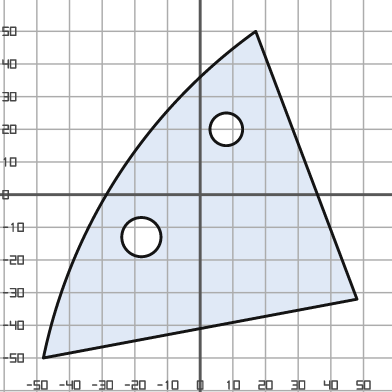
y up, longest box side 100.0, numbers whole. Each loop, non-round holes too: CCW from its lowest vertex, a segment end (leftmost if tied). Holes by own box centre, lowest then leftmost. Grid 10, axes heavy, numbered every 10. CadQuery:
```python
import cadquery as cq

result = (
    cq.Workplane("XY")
    .moveTo(-48.0, -50.0)
    .lineTo(48.0, -32.0)
    .lineTo(17.0, 50.0)
    .threePointArc((-25.0, 6.0), (-48.0, -50.0))
    .close()
    .moveTo(-18.0, -13.0)
    .circle(6.0)
    .moveTo(8.0, 20.0)
    .circle(5.0)
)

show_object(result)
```